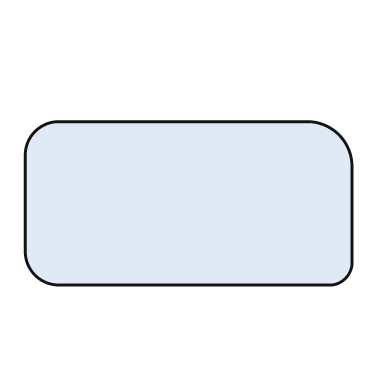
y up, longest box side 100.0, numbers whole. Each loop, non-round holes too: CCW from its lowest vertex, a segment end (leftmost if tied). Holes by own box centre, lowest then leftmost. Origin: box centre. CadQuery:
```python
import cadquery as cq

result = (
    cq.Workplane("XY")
    .moveTo(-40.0, -25.0)
    .lineTo(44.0, -25.0)
    .threePointArc((48.0, -23.0), (50.0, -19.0))
    .lineTo(50.0, 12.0)
    .threePointArc((46.0, 21.0), (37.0, 25.0))
    .lineTo(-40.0, 25.0)
    .threePointArc((-47.0, 22.0), (-50.0, 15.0))
    .lineTo(-50.0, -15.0)
    .threePointArc((-47.0, -22.0), (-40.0, -25.0))
    .close()
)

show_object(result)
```